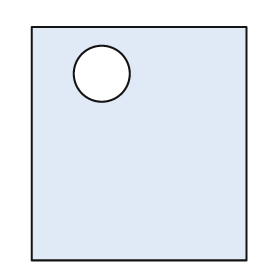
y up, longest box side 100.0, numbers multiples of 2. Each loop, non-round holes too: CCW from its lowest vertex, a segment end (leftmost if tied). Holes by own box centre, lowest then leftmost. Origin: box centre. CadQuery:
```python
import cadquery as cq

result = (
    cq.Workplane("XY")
    .moveTo(-46.0, -50.0)
    .lineTo(46.0, -50.0)
    .lineTo(46.0, 50.0)
    .lineTo(-46.0, 50.0)
    .close()
    .moveTo(-16.0, 30.0)
    .circle(12.0)
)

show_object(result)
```